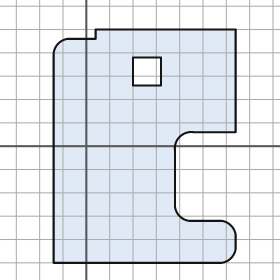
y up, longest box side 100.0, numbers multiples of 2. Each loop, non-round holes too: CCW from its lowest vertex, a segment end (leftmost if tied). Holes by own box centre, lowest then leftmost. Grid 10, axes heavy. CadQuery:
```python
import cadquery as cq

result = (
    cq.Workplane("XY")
    .moveTo(-14.0, -50.0)
    .lineTo(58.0, -50.0)
    .threePointArc((62.0, -48.0), (64.0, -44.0))
    .lineTo(64.0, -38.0)
    .threePointArc((62.0, -34.0), (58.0, -32.0))
    .lineTo(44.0, -32.0)
    .threePointArc((40.0, -30.0), (38.0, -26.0))
    .lineTo(38.0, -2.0)
    .threePointArc((40.0, 4.0), (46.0, 6.0))
    .lineTo(64.0, 6.0)
    .lineTo(64.0, 50.0)
    .lineTo(4.0, 50.0)
    .lineTo(4.0, 46.0)
    .lineTo(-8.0, 46.0)
    .threePointArc((-12.0, 44.0), (-14.0, 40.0))
    .close()
    .moveTo(20.0, 26.0)
    .lineTo(32.0, 26.0)
    .lineTo(32.0, 38.0)
    .lineTo(20.0, 38.0)
    .close()
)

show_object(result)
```